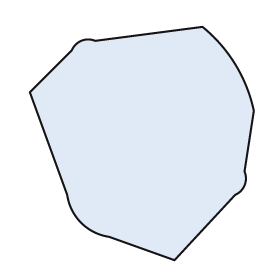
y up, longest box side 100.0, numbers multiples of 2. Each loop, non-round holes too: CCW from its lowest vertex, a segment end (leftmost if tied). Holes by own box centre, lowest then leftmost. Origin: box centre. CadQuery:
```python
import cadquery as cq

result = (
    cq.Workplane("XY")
    .moveTo(14.0, -50.0)
    .lineTo(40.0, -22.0)
    .threePointArc((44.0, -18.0), (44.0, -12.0))
    .lineTo(48.0, 14.0)
    .threePointArc((40.0, 34.0), (26.0, 50.0))
    .lineTo(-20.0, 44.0)
    .threePointArc((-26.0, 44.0), (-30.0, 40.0))
    .lineTo(-48.0, 22.0)
    .lineTo(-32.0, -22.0)
    .threePointArc((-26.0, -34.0), (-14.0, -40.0))
    .close()
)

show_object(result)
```